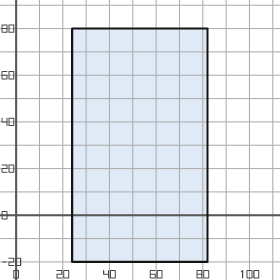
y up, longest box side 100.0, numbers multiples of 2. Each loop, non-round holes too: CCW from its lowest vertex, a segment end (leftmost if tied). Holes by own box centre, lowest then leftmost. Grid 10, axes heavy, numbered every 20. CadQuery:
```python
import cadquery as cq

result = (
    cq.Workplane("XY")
    .moveTo(24.0, -20.0)
    .lineTo(82.0, -20.0)
    .lineTo(82.0, 80.0)
    .lineTo(24.0, 80.0)
    .close()
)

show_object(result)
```